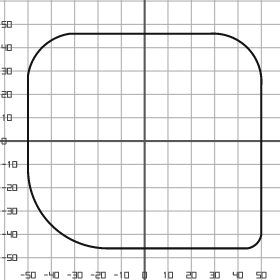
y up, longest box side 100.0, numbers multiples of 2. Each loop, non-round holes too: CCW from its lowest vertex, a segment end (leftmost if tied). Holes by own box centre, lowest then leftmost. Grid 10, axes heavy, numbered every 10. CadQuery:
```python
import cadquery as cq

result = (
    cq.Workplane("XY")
    .moveTo(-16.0, -46.0)
    .lineTo(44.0, -46.0)
    .threePointArc((48.0, -44.0), (50.0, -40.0))
    .lineTo(50.0, 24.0)
    .threePointArc((44.0, 40.0), (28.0, 46.0))
    .lineTo(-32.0, 46.0)
    .threePointArc((-44.0, 40.0), (-50.0, 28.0))
    .lineTo(-50.0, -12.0)
    .threePointArc((-40.0, -36.0), (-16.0, -46.0))
    .close()
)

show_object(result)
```